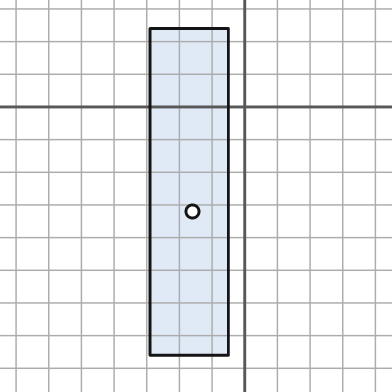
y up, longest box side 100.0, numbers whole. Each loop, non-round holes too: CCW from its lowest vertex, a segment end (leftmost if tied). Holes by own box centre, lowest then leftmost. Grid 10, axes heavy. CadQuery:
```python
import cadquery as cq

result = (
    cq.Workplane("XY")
    .moveTo(-29.0, -76.0)
    .lineTo(-5.0, -76.0)
    .lineTo(-5.0, 24.0)
    .lineTo(-29.0, 24.0)
    .close()
    .moveTo(-16.0, -32.0)
    .circle(2.0)
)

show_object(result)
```